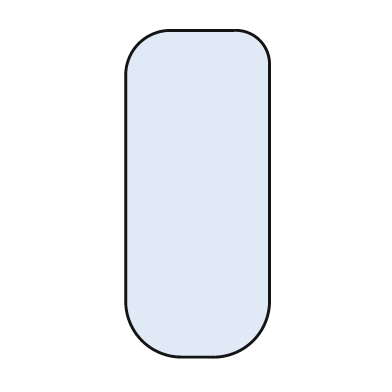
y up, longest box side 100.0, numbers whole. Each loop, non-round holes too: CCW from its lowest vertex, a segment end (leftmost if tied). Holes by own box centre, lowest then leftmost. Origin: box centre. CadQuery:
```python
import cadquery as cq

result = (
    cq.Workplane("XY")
    .moveTo(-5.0, -50.0)
    .lineTo(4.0, -50.0)
    .threePointArc((17.0, -45.0), (22.0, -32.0))
    .lineTo(22.0, 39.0)
    .threePointArc((19.0, 47.0), (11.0, 50.0))
    .lineTo(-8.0, 50.0)
    .threePointArc((-18.0, 46.0), (-22.0, 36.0))
    .lineTo(-22.0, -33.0)
    .threePointArc((-17.0, -45.0), (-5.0, -50.0))
    .close()
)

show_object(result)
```